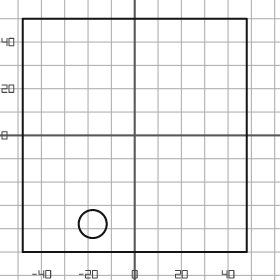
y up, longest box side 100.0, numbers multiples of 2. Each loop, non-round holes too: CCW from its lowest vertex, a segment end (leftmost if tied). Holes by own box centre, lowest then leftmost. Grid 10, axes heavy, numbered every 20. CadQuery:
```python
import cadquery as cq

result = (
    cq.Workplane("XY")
    .moveTo(-48.0, -50.0)
    .lineTo(48.0, -50.0)
    .lineTo(48.0, 50.0)
    .lineTo(-48.0, 50.0)
    .close()
    .moveTo(-18.0, -38.0)
    .circle(6.0)
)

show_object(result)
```